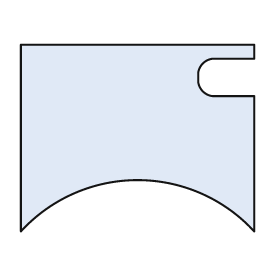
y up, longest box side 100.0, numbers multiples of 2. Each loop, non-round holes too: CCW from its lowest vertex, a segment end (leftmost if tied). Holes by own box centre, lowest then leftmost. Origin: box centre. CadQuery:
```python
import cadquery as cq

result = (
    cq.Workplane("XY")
    .moveTo(-50.0, -40.0)
    .threePointArc((0.0, -18.0), (50.0, -40.0))
    .lineTo(50.0, 18.0)
    .lineTo(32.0, 18.0)
    .threePointArc((28.0, 20.0), (26.0, 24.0))
    .lineTo(26.0, 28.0)
    .threePointArc((28.0, 32.0), (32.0, 34.0))
    .lineTo(50.0, 34.0)
    .lineTo(50.0, 40.0)
    .lineTo(-50.0, 40.0)
    .close()
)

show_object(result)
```